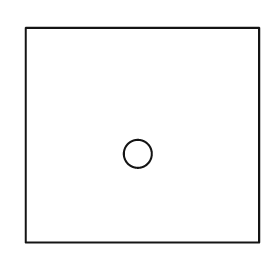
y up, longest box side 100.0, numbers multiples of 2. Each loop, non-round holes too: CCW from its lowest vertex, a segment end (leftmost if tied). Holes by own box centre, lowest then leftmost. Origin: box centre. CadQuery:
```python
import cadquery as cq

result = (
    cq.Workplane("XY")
    .moveTo(-50.0, -46.0)
    .lineTo(50.0, -46.0)
    .lineTo(50.0, 46.0)
    .lineTo(-50.0, 46.0)
    .close()
    .moveTo(-2.0, -8.0)
    .circle(6.0)
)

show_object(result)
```